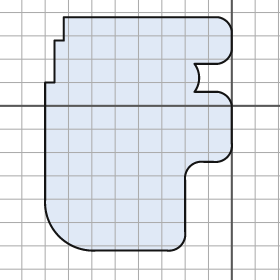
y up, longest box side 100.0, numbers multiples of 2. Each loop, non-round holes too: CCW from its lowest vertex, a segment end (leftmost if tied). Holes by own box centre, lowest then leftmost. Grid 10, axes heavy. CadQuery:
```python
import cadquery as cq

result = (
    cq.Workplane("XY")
    .moveTo(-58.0, -62.0)
    .lineTo(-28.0, -62.0)
    .threePointArc((-22.0, -60.0), (-20.0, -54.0))
    .lineTo(-20.0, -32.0)
    .threePointArc((-18.0, -26.0), (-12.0, -24.0))
    .lineTo(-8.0, -24.0)
    .threePointArc((-2.0, -22.0), (0.0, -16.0))
    .lineTo(0.0, 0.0)
    .threePointArc((-2.0, 4.0), (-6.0, 6.0))
    .lineTo(-16.0, 6.0)
    .threePointArc((-14.0, 12.0), (-16.0, 18.0))
    .lineTo(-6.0, 18.0)
    .threePointArc((-2.0, 20.0), (0.0, 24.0))
    .lineTo(0.0, 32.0)
    .threePointArc((-2.0, 36.0), (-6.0, 38.0))
    .lineTo(-72.0, 38.0)
    .lineTo(-72.0, 28.0)
    .lineTo(-76.0, 28.0)
    .lineTo(-76.0, 10.0)
    .lineTo(-80.0, 10.0)
    .lineTo(-80.0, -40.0)
    .threePointArc((-74.0, -56.0), (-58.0, -62.0))
    .close()
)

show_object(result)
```